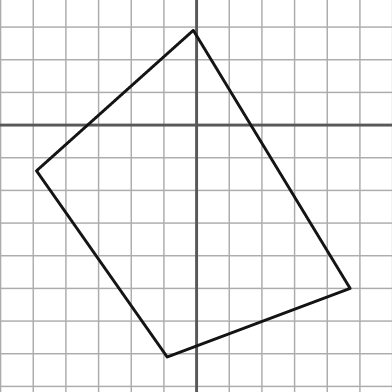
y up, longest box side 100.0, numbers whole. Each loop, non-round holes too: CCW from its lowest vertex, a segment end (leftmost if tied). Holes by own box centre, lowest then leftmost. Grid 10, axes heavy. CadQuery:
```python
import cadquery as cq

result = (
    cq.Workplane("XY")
    .moveTo(-9.0, -71.0)
    .lineTo(47.0, -50.0)
    .lineTo(-1.0, 29.0)
    .lineTo(-49.0, -14.0)
    .close()
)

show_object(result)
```